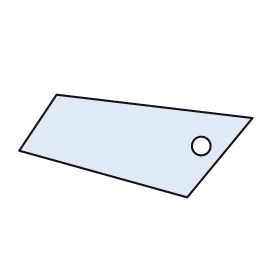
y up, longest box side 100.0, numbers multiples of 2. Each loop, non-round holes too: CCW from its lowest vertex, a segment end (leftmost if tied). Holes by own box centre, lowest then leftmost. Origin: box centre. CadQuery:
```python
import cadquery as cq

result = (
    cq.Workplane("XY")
    .moveTo(22.0, -22.0)
    .lineTo(50.0, 12.0)
    .lineTo(-34.0, 22.0)
    .lineTo(-50.0, -2.0)
    .close()
    .moveTo(28.0, 0.0)
    .circle(4.0)
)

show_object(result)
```